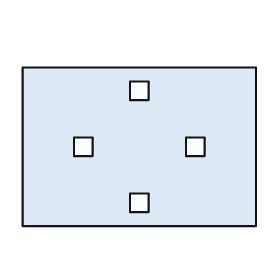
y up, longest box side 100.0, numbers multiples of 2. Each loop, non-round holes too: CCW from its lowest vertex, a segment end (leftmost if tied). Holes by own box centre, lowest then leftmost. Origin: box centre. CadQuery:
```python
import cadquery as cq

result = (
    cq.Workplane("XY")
    .moveTo(-50.0, -34.0)
    .lineTo(50.0, -34.0)
    .lineTo(50.0, 34.0)
    .lineTo(-50.0, 34.0)
    .close()
    .moveTo(-4.0, -28.0)
    .lineTo(4.0, -28.0)
    .lineTo(4.0, -20.0)
    .lineTo(-4.0, -20.0)
    .close()
    .moveTo(-28.0, -4.0)
    .lineTo(-20.0, -4.0)
    .lineTo(-20.0, 4.0)
    .lineTo(-28.0, 4.0)
    .close()
    .moveTo(20.0, -4.0)
    .lineTo(28.0, -4.0)
    .lineTo(28.0, 4.0)
    .lineTo(20.0, 4.0)
    .close()
    .moveTo(-4.0, 20.0)
    .lineTo(4.0, 20.0)
    .lineTo(4.0, 28.0)
    .lineTo(-4.0, 28.0)
    .close()
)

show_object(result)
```